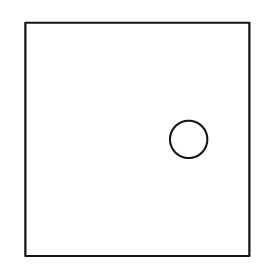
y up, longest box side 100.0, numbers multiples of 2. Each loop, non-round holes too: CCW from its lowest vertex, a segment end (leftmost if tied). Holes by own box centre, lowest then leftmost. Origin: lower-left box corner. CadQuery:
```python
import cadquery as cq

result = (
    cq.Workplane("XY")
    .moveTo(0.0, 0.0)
    .lineTo(96.0, 0.0)
    .lineTo(96.0, 100.0)
    .lineTo(0.0, 100.0)
    .close()
    .moveTo(70.0, 50.0)
    .circle(8.0)
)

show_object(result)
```